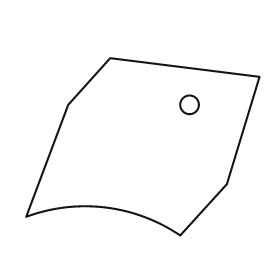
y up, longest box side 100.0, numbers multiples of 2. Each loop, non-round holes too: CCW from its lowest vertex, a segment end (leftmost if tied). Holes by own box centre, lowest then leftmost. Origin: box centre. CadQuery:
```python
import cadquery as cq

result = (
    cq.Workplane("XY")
    .moveTo(16.0, -38.0)
    .lineTo(36.0, -16.0)
    .lineTo(50.0, 30.0)
    .lineTo(-14.0, 38.0)
    .lineTo(-32.0, 18.0)
    .lineTo(-50.0, -30.0)
    .threePointArc((-16.0, -26.0), (16.0, -38.0))
    .close()
    .moveTo(20.0, 18.0)
    .circle(4.0)
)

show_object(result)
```